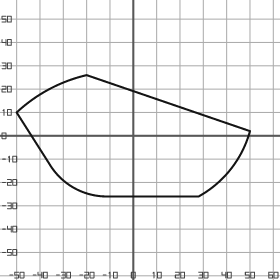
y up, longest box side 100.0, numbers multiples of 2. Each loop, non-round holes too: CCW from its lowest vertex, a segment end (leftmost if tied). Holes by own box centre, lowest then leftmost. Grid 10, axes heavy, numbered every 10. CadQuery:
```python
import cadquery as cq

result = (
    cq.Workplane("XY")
    .moveTo(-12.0, -26.0)
    .lineTo(28.0, -26.0)
    .threePointArc((42.0, -14.0), (50.0, 2.0))
    .lineTo(-20.0, 26.0)
    .threePointArc((-36.0, 20.0), (-50.0, 10.0))
    .lineTo(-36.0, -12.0)
    .threePointArc((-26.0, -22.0), (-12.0, -26.0))
    .close()
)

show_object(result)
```